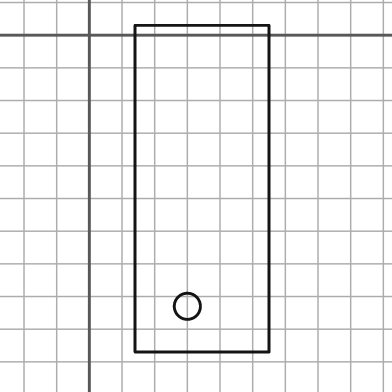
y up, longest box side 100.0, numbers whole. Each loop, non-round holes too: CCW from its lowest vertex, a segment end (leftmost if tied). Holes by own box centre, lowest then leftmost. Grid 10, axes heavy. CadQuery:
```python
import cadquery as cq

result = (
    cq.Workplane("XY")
    .moveTo(14.0, -97.0)
    .lineTo(55.0, -97.0)
    .lineTo(55.0, 3.0)
    .lineTo(14.0, 3.0)
    .close()
    .moveTo(30.0, -83.0)
    .circle(4.0)
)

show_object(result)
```